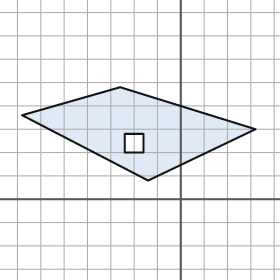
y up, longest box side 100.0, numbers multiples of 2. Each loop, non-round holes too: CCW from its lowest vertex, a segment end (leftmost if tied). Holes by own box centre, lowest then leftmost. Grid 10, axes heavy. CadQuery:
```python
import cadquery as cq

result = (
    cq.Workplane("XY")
    .moveTo(-14.0, 8.0)
    .lineTo(32.0, 30.0)
    .lineTo(-26.0, 48.0)
    .lineTo(-68.0, 36.0)
    .close()
    .moveTo(-24.0, 20.0)
    .lineTo(-16.0, 20.0)
    .lineTo(-16.0, 28.0)
    .lineTo(-24.0, 28.0)
    .close()
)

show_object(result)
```